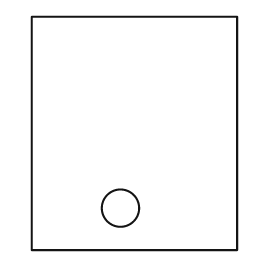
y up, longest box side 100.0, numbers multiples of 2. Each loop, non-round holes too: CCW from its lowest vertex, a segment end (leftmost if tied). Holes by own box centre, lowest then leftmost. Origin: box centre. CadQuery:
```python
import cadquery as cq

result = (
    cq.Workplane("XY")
    .moveTo(-44.0, -50.0)
    .lineTo(44.0, -50.0)
    .lineTo(44.0, 50.0)
    .lineTo(-44.0, 50.0)
    .close()
    .moveTo(-6.0, -32.0)
    .circle(8.0)
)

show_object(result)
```